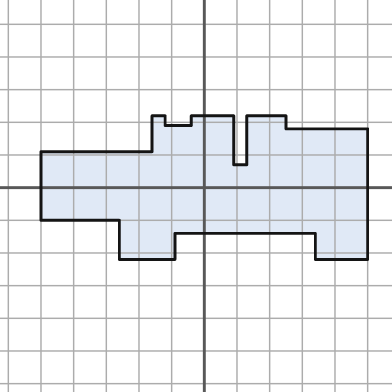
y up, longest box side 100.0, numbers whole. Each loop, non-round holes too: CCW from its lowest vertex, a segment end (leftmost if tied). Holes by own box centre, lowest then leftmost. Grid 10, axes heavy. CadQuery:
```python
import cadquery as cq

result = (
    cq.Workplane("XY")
    .moveTo(-26.0, -22.0)
    .lineTo(-9.0, -22.0)
    .lineTo(-9.0, -14.0)
    .lineTo(34.0, -14.0)
    .lineTo(34.0, -22.0)
    .lineTo(50.0, -22.0)
    .lineTo(50.0, 18.0)
    .lineTo(25.0, 18.0)
    .lineTo(25.0, 22.0)
    .lineTo(13.0, 22.0)
    .lineTo(13.0, 7.0)
    .lineTo(9.0, 7.0)
    .lineTo(9.0, 22.0)
    .lineTo(-4.0, 22.0)
    .lineTo(-4.0, 19.0)
    .lineTo(-12.0, 19.0)
    .lineTo(-12.0, 22.0)
    .lineTo(-16.0, 22.0)
    .lineTo(-16.0, 11.0)
    .lineTo(-50.0, 11.0)
    .lineTo(-50.0, -10.0)
    .lineTo(-26.0, -10.0)
    .close()
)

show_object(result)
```